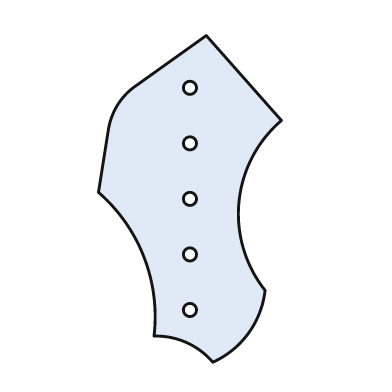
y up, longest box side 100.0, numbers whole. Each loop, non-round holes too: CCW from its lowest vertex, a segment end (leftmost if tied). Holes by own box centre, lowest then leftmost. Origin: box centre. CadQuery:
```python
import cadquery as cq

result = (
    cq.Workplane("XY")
    .moveTo(7.0, -50.0)
    .threePointArc((18.0, -41.0), (23.0, -28.0))
    .threePointArc((15.0, -1.0), (28.0, 24.0))
    .lineTo(5.0, 50.0)
    .lineTo(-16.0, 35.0)
    .threePointArc((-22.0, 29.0), (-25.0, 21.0))
    .lineTo(-28.0, 2.0)
    .threePointArc((-14.0, -18.0), (-11.0, -42.0))
    .threePointArc((-1.0, -44.0), (7.0, -50.0))
    .close()
    .moveTo(0.0, -34.0)
    .circle(2.0)
    .moveTo(0.0, -17.0)
    .circle(2.0)
    .moveTo(0.0, 0.0)
    .circle(2.0)
    .moveTo(0.0, 17.0)
    .circle(2.0)
    .moveTo(0.0, 34.0)
    .circle(2.0)
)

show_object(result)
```